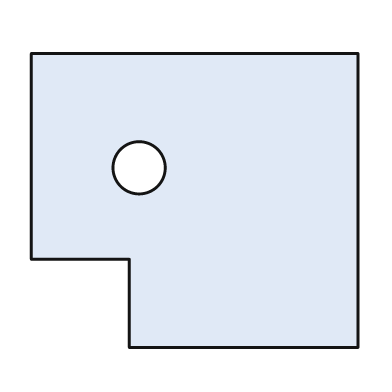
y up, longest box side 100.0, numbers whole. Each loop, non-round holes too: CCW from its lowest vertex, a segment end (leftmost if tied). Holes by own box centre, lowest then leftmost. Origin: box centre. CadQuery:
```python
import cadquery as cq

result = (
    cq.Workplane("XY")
    .moveTo(-20.0, -45.0)
    .lineTo(50.0, -45.0)
    .lineTo(50.0, 45.0)
    .lineTo(-50.0, 45.0)
    .lineTo(-50.0, -18.0)
    .lineTo(-20.0, -18.0)
    .close()
    .moveTo(-17.0, 10.0)
    .circle(8.0)
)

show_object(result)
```